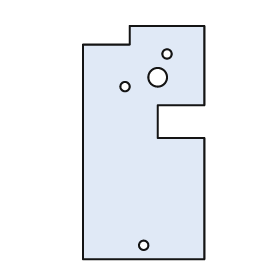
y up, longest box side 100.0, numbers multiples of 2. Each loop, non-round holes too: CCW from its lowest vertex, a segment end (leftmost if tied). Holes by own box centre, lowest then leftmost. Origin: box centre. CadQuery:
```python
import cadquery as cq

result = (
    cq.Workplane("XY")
    .moveTo(-26.0, -50.0)
    .lineTo(26.0, -50.0)
    .lineTo(26.0, 2.0)
    .lineTo(6.0, 2.0)
    .lineTo(6.0, 16.0)
    .lineTo(26.0, 16.0)
    .lineTo(26.0, 50.0)
    .lineTo(-6.0, 50.0)
    .lineTo(-6.0, 42.0)
    .lineTo(-26.0, 42.0)
    .close()
    .moveTo(0.0, -44.0)
    .circle(2.0)
    .moveTo(-8.0, 24.0)
    .circle(2.0)
    .moveTo(6.0, 28.0)
    .circle(4.0)
    .moveTo(10.0, 38.0)
    .circle(2.0)
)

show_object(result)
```